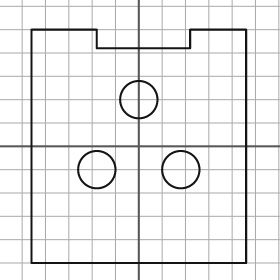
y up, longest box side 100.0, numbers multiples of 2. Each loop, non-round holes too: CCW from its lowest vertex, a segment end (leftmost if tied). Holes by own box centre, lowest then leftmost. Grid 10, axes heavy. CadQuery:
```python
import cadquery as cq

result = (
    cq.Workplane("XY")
    .moveTo(-46.0, -50.0)
    .lineTo(46.0, -50.0)
    .lineTo(46.0, 50.0)
    .lineTo(22.0, 50.0)
    .lineTo(22.0, 42.0)
    .lineTo(-18.0, 42.0)
    .lineTo(-18.0, 50.0)
    .lineTo(-46.0, 50.0)
    .close()
    .moveTo(-18.0, -10.0)
    .circle(8.0)
    .moveTo(18.0, -10.0)
    .circle(8.0)
    .moveTo(0.0, 20.0)
    .circle(8.0)
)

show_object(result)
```